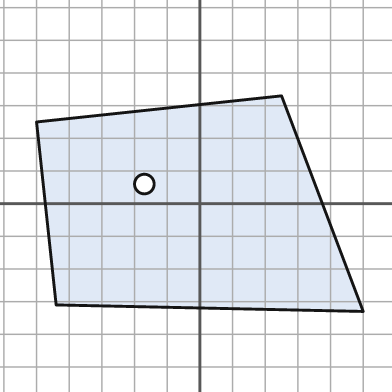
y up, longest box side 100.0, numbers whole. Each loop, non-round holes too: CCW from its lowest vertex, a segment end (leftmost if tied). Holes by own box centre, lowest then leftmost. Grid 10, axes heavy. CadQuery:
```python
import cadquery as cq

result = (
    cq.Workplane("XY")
    .moveTo(50.0, -33.0)
    .lineTo(25.0, 33.0)
    .lineTo(-50.0, 25.0)
    .lineTo(-44.0, -31.0)
    .close()
    .moveTo(-17.0, 6.0)
    .circle(3.0)
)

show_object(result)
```